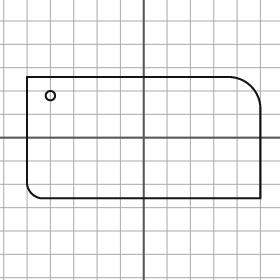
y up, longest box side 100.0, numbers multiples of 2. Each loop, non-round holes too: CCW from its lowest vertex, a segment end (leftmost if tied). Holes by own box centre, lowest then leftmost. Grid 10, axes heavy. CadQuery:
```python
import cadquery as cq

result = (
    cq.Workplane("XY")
    .moveTo(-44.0, -26.0)
    .lineTo(50.0, -26.0)
    .lineTo(50.0, 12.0)
    .threePointArc((46.0, 22.0), (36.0, 26.0))
    .lineTo(-50.0, 26.0)
    .lineTo(-50.0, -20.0)
    .threePointArc((-48.0, -24.0), (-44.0, -26.0))
    .close()
    .moveTo(-40.0, 18.0)
    .circle(2.0)
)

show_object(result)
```